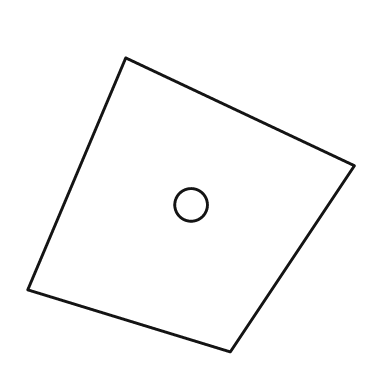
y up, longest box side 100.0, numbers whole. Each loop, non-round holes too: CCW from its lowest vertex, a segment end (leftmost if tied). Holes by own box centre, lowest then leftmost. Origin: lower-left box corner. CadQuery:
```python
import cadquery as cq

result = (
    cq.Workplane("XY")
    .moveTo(62.0, 0.0)
    .lineTo(100.0, 57.0)
    .lineTo(30.0, 90.0)
    .lineTo(0.0, 19.0)
    .close()
    .moveTo(50.0, 45.0)
    .circle(5.0)
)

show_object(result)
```